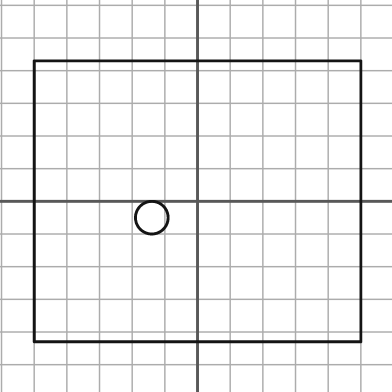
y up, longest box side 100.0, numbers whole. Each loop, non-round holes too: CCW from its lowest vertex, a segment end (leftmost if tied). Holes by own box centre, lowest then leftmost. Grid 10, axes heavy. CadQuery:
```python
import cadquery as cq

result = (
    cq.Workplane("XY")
    .moveTo(-50.0, -43.0)
    .lineTo(50.0, -43.0)
    .lineTo(50.0, 43.0)
    .lineTo(-50.0, 43.0)
    .close()
    .moveTo(-14.0, -5.0)
    .circle(5.0)
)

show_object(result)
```